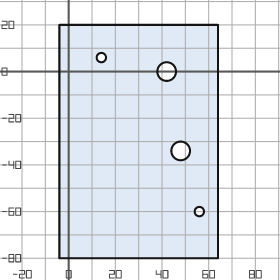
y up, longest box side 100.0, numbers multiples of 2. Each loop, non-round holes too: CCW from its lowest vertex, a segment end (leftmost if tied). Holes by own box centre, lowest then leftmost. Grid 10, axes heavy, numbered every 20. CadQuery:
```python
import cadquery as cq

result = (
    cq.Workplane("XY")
    .moveTo(-4.0, -80.0)
    .lineTo(64.0, -80.0)
    .lineTo(64.0, 20.0)
    .lineTo(-4.0, 20.0)
    .close()
    .moveTo(56.0, -60.0)
    .circle(2.0)
    .moveTo(48.0, -34.0)
    .circle(4.0)
    .moveTo(42.0, 0.0)
    .circle(4.0)
    .moveTo(14.0, 6.0)
    .circle(2.0)
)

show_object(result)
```